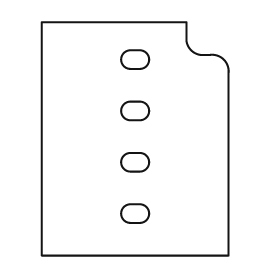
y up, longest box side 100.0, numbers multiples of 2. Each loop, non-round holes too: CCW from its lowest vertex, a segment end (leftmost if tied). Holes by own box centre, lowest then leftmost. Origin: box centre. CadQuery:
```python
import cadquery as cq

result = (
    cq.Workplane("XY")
    .moveTo(-40.0, -50.0)
    .lineTo(40.0, -50.0)
    .lineTo(40.0, 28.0)
    .threePointArc((38.0, 34.0), (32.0, 36.0))
    .lineTo(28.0, 36.0)
    .threePointArc((24.0, 38.0), (22.0, 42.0))
    .lineTo(22.0, 50.0)
    .lineTo(-40.0, 50.0)
    .close()
    .moveTo(-2.0, -36.0)
    .lineTo(2.0, -36.0)
    .threePointArc((6.0, -32.0), (2.0, -28.0))
    .lineTo(-2.0, -28.0)
    .threePointArc((-6.0, -32.0), (-2.0, -36.0))
    .close()
    .moveTo(-2.0, -14.0)
    .lineTo(2.0, -14.0)
    .threePointArc((6.0, -10.0), (2.0, -6.0))
    .lineTo(-2.0, -6.0)
    .threePointArc((-6.0, -10.0), (-2.0, -14.0))
    .close()
    .moveTo(-2.0, 8.0)
    .lineTo(2.0, 8.0)
    .threePointArc((6.0, 12.0), (2.0, 16.0))
    .lineTo(-2.0, 16.0)
    .threePointArc((-6.0, 12.0), (-2.0, 8.0))
    .close()
    .moveTo(-2.0, 30.0)
    .lineTo(2.0, 30.0)
    .threePointArc((6.0, 34.0), (2.0, 38.0))
    .lineTo(-2.0, 38.0)
    .threePointArc((-6.0, 34.0), (-2.0, 30.0))
    .close()
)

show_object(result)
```